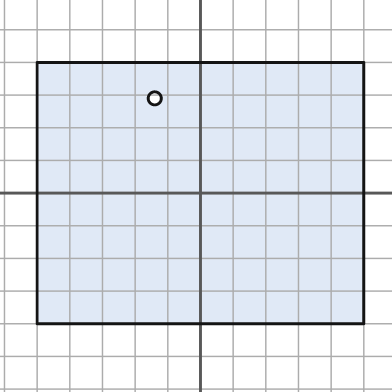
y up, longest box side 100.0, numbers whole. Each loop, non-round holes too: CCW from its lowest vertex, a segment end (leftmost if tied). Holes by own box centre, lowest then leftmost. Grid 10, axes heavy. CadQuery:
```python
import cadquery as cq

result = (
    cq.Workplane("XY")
    .moveTo(-50.0, -40.0)
    .lineTo(50.0, -40.0)
    .lineTo(50.0, 40.0)
    .lineTo(-50.0, 40.0)
    .close()
    .moveTo(-14.0, 29.0)
    .circle(2.0)
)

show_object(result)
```